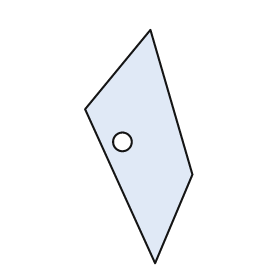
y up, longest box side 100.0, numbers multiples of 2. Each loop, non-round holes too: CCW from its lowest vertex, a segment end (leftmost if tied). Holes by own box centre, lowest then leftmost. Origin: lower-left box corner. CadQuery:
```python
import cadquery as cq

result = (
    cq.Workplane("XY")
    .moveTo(30.0, 0.0)
    .lineTo(46.0, 38.0)
    .lineTo(28.0, 100.0)
    .lineTo(0.0, 66.0)
    .close()
    .moveTo(16.0, 52.0)
    .circle(4.0)
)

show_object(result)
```